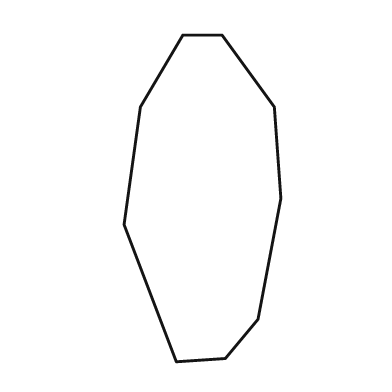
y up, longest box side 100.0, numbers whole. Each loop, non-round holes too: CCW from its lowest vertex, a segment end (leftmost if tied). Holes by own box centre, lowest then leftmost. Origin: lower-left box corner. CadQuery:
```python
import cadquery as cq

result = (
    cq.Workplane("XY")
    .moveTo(16.0, 0.0)
    .lineTo(31.0, 1.0)
    .lineTo(41.0, 13.0)
    .lineTo(48.0, 50.0)
    .lineTo(46.0, 78.0)
    .lineTo(30.0, 100.0)
    .lineTo(18.0, 100.0)
    .lineTo(5.0, 78.0)
    .lineTo(0.0, 42.0)
    .close()
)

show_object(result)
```